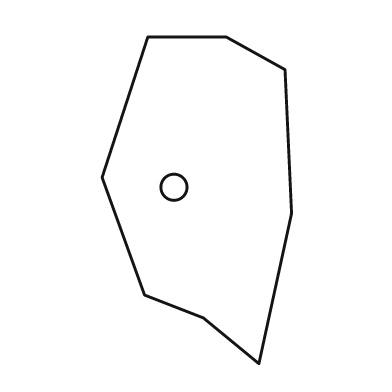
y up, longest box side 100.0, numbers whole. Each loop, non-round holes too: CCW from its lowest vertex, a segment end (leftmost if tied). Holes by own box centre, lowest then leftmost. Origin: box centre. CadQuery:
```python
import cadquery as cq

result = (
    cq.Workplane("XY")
    .moveTo(19.0, -50.0)
    .lineTo(29.0, -4.0)
    .lineTo(27.0, 40.0)
    .lineTo(9.0, 50.0)
    .lineTo(-15.0, 50.0)
    .lineTo(-29.0, 7.0)
    .lineTo(-16.0, -29.0)
    .lineTo(2.0, -36.0)
    .close()
    .moveTo(-7.0, 4.0)
    .circle(4.0)
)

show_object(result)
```